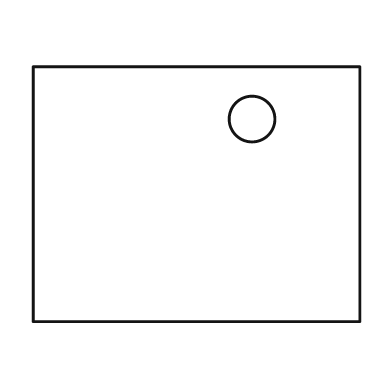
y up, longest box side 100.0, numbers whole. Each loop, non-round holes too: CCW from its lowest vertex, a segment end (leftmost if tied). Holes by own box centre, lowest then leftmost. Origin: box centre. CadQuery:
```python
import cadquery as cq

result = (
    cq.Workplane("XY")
    .moveTo(-50.0, -39.0)
    .lineTo(50.0, -39.0)
    .lineTo(50.0, 39.0)
    .lineTo(-50.0, 39.0)
    .close()
    .moveTo(17.0, 23.0)
    .circle(7.0)
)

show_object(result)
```